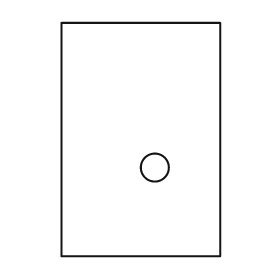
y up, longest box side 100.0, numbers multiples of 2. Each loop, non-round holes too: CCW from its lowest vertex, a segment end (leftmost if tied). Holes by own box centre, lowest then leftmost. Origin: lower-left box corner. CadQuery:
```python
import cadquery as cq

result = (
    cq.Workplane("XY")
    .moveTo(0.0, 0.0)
    .lineTo(68.0, 0.0)
    .lineTo(68.0, 100.0)
    .lineTo(0.0, 100.0)
    .close()
    .moveTo(40.0, 38.0)
    .circle(6.0)
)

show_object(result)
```